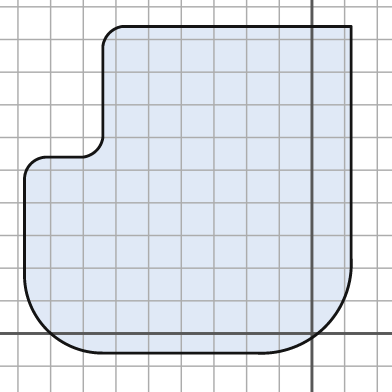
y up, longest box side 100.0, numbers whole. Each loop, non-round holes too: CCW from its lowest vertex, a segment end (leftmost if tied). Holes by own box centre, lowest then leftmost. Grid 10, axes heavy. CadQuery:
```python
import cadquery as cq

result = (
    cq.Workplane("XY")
    .moveTo(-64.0, -6.0)
    .lineTo(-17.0, -6.0)
    .threePointArc((4.0, 2.0), (12.0, 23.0))
    .lineTo(12.0, 94.0)
    .lineTo(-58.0, 94.0)
    .threePointArc((-62.0, 92.0), (-64.0, 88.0))
    .lineTo(-64.0, 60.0)
    .threePointArc((-66.0, 56.0), (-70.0, 54.0))
    .lineTo(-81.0, 54.0)
    .threePointArc((-86.0, 52.0), (-88.0, 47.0))
    .lineTo(-88.0, 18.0)
    .threePointArc((-81.0, 1.0), (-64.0, -6.0))
    .close()
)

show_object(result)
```